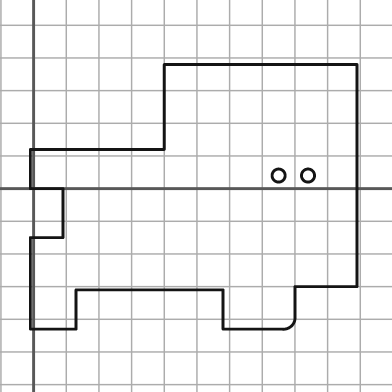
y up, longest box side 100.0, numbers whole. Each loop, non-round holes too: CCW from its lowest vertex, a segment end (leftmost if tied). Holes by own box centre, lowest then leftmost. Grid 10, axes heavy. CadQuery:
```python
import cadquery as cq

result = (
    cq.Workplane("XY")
    .moveTo(-1.0, -43.0)
    .lineTo(13.0, -43.0)
    .lineTo(13.0, -31.0)
    .lineTo(58.0, -31.0)
    .lineTo(58.0, -43.0)
    .lineTo(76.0, -43.0)
    .threePointArc((79.0, -42.0), (80.0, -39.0))
    .lineTo(80.0, -30.0)
    .lineTo(99.0, -30.0)
    .lineTo(99.0, 38.0)
    .lineTo(40.0, 38.0)
    .lineTo(40.0, 12.0)
    .lineTo(-1.0, 12.0)
    .lineTo(-1.0, 0.0)
    .lineTo(9.0, 0.0)
    .lineTo(9.0, -15.0)
    .lineTo(-1.0, -15.0)
    .close()
    .moveTo(75.0, 4.0)
    .circle(2.0)
    .moveTo(84.0, 4.0)
    .circle(2.0)
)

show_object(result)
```